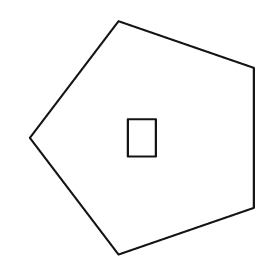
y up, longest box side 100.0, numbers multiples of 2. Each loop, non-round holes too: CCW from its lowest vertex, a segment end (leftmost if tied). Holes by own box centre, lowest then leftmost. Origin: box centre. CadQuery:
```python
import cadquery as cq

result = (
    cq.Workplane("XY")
    .moveTo(-10.0, -50.0)
    .lineTo(48.0, -30.0)
    .lineTo(48.0, 30.0)
    .lineTo(-10.0, 50.0)
    .lineTo(-48.0, 0.0)
    .close()
    .moveTo(-6.0, -8.0)
    .lineTo(6.0, -8.0)
    .lineTo(6.0, 8.0)
    .lineTo(-6.0, 8.0)
    .close()
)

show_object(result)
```